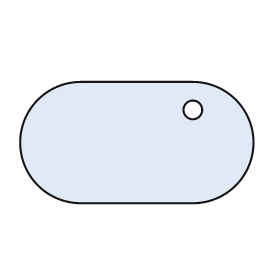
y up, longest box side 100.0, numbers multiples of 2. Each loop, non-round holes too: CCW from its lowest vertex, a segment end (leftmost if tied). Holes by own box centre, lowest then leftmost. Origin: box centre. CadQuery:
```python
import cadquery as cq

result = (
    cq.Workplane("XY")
    .moveTo(-24.0, -26.0)
    .lineTo(24.0, -26.0)
    .threePointArc((50.0, 0.0), (24.0, 26.0))
    .lineTo(-24.0, 26.0)
    .threePointArc((-50.0, 0.0), (-24.0, -26.0))
    .close()
    .moveTo(24.0, 14.0)
    .circle(4.0)
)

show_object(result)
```